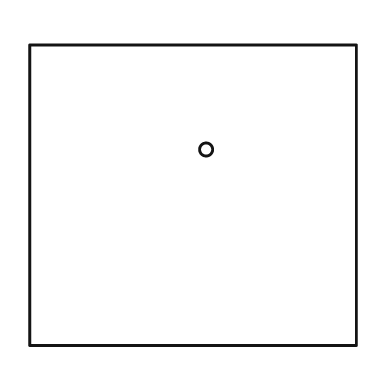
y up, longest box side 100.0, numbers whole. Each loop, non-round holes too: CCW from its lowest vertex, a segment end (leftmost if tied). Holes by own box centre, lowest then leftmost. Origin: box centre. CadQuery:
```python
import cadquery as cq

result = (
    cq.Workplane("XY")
    .moveTo(-50.0, -46.0)
    .lineTo(50.0, -46.0)
    .lineTo(50.0, 46.0)
    .lineTo(-50.0, 46.0)
    .close()
    .moveTo(4.0, 14.0)
    .circle(2.0)
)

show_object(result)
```